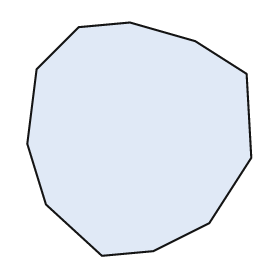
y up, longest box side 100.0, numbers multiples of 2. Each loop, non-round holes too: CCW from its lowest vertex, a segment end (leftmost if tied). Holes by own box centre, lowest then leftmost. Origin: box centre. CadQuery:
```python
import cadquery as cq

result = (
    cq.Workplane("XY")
    .moveTo(-16.0, -50.0)
    .lineTo(6.0, -48.0)
    .lineTo(30.0, -36.0)
    .lineTo(48.0, -8.0)
    .lineTo(46.0, 28.0)
    .lineTo(24.0, 42.0)
    .lineTo(-4.0, 50.0)
    .lineTo(-26.0, 48.0)
    .lineTo(-44.0, 30.0)
    .lineTo(-48.0, -2.0)
    .lineTo(-40.0, -28.0)
    .close()
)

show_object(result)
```